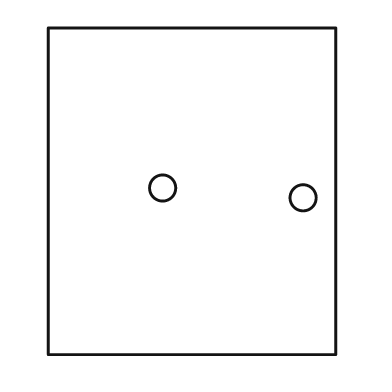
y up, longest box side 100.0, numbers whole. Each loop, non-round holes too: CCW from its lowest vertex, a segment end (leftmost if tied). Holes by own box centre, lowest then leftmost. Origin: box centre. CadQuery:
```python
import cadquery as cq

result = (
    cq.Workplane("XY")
    .moveTo(-44.0, -50.0)
    .lineTo(44.0, -50.0)
    .lineTo(44.0, 50.0)
    .lineTo(-44.0, 50.0)
    .close()
    .moveTo(34.0, -2.0)
    .circle(4.0)
    .moveTo(-9.0, 1.0)
    .circle(4.0)
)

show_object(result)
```